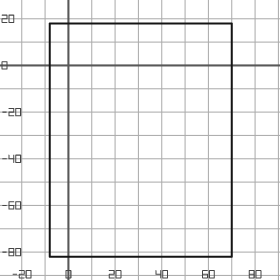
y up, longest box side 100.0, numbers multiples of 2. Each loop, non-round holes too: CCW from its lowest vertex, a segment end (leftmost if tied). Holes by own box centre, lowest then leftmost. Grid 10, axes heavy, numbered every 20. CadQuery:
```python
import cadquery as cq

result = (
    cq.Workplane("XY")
    .moveTo(-8.0, -82.0)
    .lineTo(70.0, -82.0)
    .lineTo(70.0, 18.0)
    .lineTo(-8.0, 18.0)
    .close()
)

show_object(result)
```